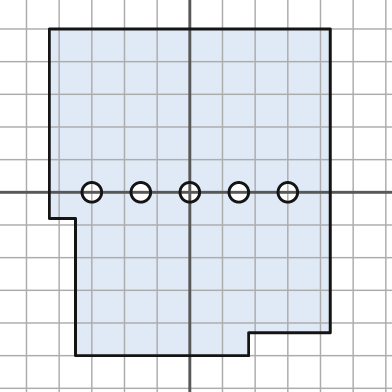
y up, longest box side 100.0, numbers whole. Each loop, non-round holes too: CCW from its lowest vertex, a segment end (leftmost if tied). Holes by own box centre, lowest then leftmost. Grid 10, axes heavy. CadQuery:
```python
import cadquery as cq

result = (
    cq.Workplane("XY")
    .moveTo(-35.0, -50.0)
    .lineTo(18.0, -50.0)
    .lineTo(18.0, -43.0)
    .lineTo(43.0, -43.0)
    .lineTo(43.0, 50.0)
    .lineTo(-43.0, 50.0)
    .lineTo(-43.0, -8.0)
    .lineTo(-35.0, -8.0)
    .close()
    .moveTo(-30.0, 0.0)
    .circle(3.0)
    .moveTo(-15.0, 0.0)
    .circle(3.0)
    .moveTo(0.0, 0.0)
    .circle(3.0)
    .moveTo(15.0, 0.0)
    .circle(3.0)
    .moveTo(30.0, 0.0)
    .circle(3.0)
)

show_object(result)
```